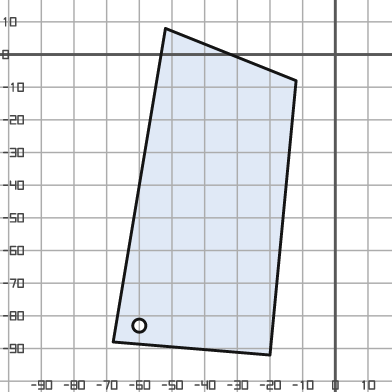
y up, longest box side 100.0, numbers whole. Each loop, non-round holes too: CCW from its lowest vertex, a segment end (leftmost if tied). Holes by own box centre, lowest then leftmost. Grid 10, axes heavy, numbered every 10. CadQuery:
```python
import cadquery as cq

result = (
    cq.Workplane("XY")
    .moveTo(-20.0, -92.0)
    .lineTo(-12.0, -8.0)
    .lineTo(-52.0, 8.0)
    .lineTo(-68.0, -88.0)
    .close()
    .moveTo(-60.0, -83.0)
    .circle(2.0)
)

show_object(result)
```